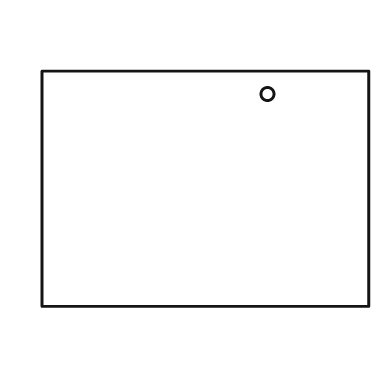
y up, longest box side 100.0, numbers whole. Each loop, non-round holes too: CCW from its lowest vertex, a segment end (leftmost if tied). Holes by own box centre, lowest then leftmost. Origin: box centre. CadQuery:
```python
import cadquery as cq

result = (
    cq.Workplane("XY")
    .moveTo(-50.0, -36.0)
    .lineTo(50.0, -36.0)
    .lineTo(50.0, 36.0)
    .lineTo(-50.0, 36.0)
    .close()
    .moveTo(19.0, 29.0)
    .circle(2.0)
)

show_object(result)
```